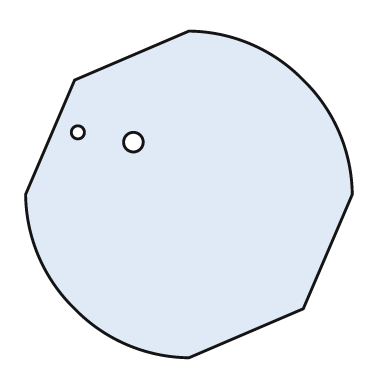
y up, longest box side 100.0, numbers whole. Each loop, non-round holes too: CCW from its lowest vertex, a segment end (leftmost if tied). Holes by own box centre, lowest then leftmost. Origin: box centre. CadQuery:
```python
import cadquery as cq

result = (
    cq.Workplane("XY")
    .moveTo(0.0, -50.0)
    .lineTo(35.0, -35.0)
    .lineTo(50.0, 0.0)
    .threePointArc((46.0, 19.0), (35.0, 35.0))
    .threePointArc((19.0, 46.0), (0.0, 50.0))
    .lineTo(-35.0, 35.0)
    .lineTo(-50.0, 0.0)
    .threePointArc((-46.0, -19.0), (-35.0, -35.0))
    .threePointArc((-19.0, -46.0), (0.0, -50.0))
    .close()
    .moveTo(-17.0, 16.0)
    .circle(3.0)
    .moveTo(-34.0, 19.0)
    .circle(2.0)
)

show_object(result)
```